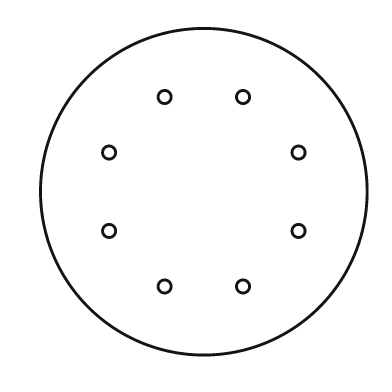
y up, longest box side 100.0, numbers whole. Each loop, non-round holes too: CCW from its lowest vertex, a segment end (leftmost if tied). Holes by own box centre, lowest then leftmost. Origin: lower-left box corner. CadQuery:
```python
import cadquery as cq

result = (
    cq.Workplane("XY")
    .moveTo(50.0, 50.0)
    .circle(50.0)
    .moveTo(38.0, 21.0)
    .circle(2.0)
    .moveTo(62.0, 21.0)
    .circle(2.0)
    .moveTo(21.0, 38.0)
    .circle(2.0)
    .moveTo(79.0, 38.0)
    .circle(2.0)
    .moveTo(21.0, 62.0)
    .circle(2.0)
    .moveTo(79.0, 62.0)
    .circle(2.0)
    .moveTo(38.0, 79.0)
    .circle(2.0)
    .moveTo(62.0, 79.0)
    .circle(2.0)
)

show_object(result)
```